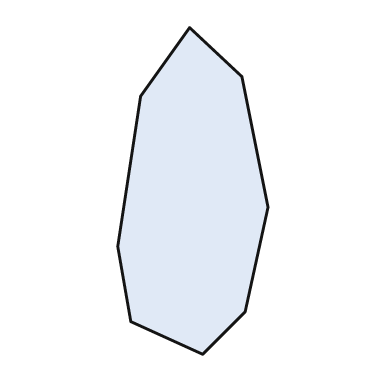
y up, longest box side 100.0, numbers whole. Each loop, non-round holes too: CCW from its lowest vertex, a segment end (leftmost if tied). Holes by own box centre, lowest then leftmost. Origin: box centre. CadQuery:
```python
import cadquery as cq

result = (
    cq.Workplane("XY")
    .moveTo(3.0, -50.0)
    .lineTo(16.0, -37.0)
    .lineTo(23.0, -5.0)
    .lineTo(15.0, 35.0)
    .lineTo(-1.0, 50.0)
    .lineTo(-16.0, 29.0)
    .lineTo(-23.0, -17.0)
    .lineTo(-19.0, -40.0)
    .close()
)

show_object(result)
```